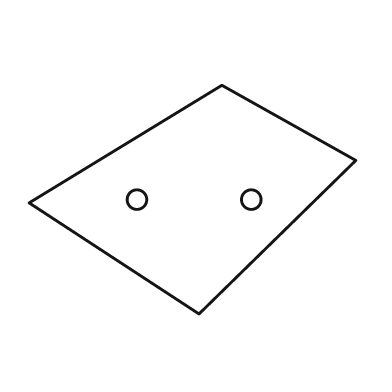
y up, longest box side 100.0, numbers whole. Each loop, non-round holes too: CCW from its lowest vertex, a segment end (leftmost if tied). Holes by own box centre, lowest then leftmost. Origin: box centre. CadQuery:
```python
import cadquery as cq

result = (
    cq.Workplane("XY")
    .moveTo(2.0, -35.0)
    .lineTo(50.0, 12.0)
    .lineTo(9.0, 35.0)
    .lineTo(-50.0, -1.0)
    .close()
    .moveTo(-17.0, 0.0)
    .circle(3.0)
    .moveTo(18.0, 0.0)
    .circle(3.0)
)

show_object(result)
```